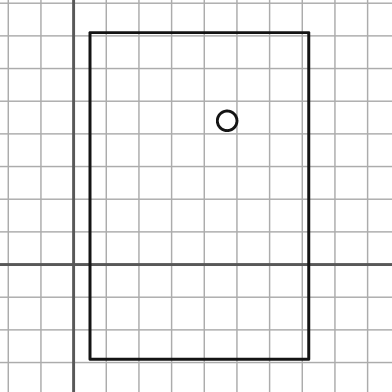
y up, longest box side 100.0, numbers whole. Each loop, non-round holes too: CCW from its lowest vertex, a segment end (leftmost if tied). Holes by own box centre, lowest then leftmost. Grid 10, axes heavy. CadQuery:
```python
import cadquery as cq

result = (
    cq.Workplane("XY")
    .moveTo(5.0, -29.0)
    .lineTo(72.0, -29.0)
    .lineTo(72.0, 71.0)
    .lineTo(5.0, 71.0)
    .close()
    .moveTo(47.0, 44.0)
    .circle(3.0)
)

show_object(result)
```